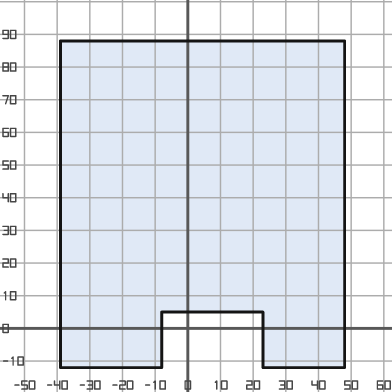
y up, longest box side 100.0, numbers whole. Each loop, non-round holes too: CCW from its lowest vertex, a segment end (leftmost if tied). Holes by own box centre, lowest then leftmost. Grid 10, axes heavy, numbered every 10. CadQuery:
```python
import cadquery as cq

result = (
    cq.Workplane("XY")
    .moveTo(-39.0, -12.0)
    .lineTo(-8.0, -12.0)
    .lineTo(-8.0, 5.0)
    .lineTo(23.0, 5.0)
    .lineTo(23.0, -12.0)
    .lineTo(48.0, -12.0)
    .lineTo(48.0, 88.0)
    .lineTo(-39.0, 88.0)
    .close()
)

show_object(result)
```